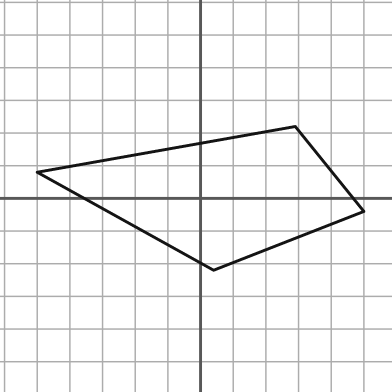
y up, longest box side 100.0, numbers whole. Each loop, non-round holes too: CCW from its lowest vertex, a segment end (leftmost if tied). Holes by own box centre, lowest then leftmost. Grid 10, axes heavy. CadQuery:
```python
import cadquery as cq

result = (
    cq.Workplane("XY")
    .moveTo(4.0, -22.0)
    .lineTo(50.0, -4.0)
    .lineTo(29.0, 22.0)
    .lineTo(-50.0, 8.0)
    .close()
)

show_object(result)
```